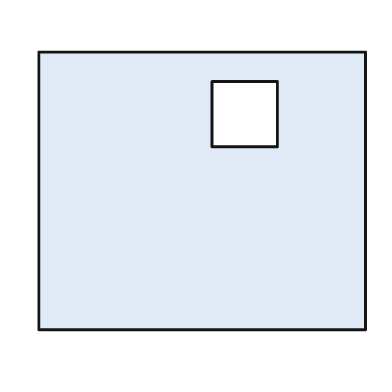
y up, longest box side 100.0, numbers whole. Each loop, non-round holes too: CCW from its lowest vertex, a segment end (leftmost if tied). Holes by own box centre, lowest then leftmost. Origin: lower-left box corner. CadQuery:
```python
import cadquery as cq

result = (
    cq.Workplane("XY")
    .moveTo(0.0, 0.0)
    .lineTo(100.0, 0.0)
    .lineTo(100.0, 85.0)
    .lineTo(0.0, 85.0)
    .close()
    .moveTo(53.0, 56.0)
    .lineTo(73.0, 56.0)
    .lineTo(73.0, 76.0)
    .lineTo(53.0, 76.0)
    .close()
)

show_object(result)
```